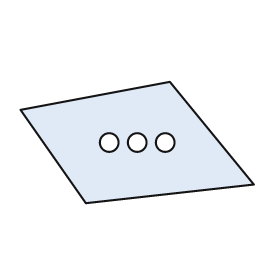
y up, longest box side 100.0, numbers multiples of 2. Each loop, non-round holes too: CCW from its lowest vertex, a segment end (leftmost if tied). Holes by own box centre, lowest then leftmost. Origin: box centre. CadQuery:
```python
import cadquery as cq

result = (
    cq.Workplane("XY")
    .moveTo(-22.0, -26.0)
    .lineTo(50.0, -18.0)
    .lineTo(14.0, 26.0)
    .lineTo(-50.0, 14.0)
    .close()
    .moveTo(-12.0, 0.0)
    .circle(4.0)
    .moveTo(0.0, 0.0)
    .circle(4.0)
    .moveTo(12.0, 0.0)
    .circle(4.0)
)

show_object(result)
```